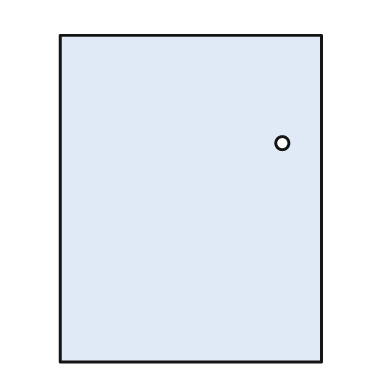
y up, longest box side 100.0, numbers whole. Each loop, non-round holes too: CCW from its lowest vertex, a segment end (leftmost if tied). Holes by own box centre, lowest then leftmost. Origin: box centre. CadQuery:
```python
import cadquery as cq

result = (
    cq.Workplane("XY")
    .moveTo(-40.0, -50.0)
    .lineTo(40.0, -50.0)
    .lineTo(40.0, 50.0)
    .lineTo(-40.0, 50.0)
    .close()
    .moveTo(28.0, 17.0)
    .circle(2.0)
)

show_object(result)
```